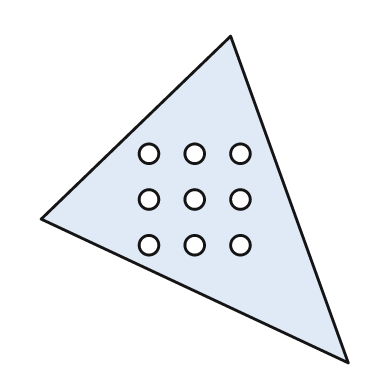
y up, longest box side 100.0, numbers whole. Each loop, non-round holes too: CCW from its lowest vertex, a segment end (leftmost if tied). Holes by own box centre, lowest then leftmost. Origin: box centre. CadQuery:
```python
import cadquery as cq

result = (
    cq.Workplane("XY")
    .moveTo(47.0, -50.0)
    .lineTo(11.0, 50.0)
    .lineTo(-47.0, -6.0)
    .close()
    .moveTo(-14.0, -14.0)
    .circle(3.0)
    .moveTo(0.0, -14.0)
    .circle(3.0)
    .moveTo(14.0, -14.0)
    .circle(3.0)
    .moveTo(-14.0, 0.0)
    .circle(3.0)
    .moveTo(0.0, 0.0)
    .circle(3.0)
    .moveTo(14.0, 0.0)
    .circle(3.0)
    .moveTo(-14.0, 14.0)
    .circle(3.0)
    .moveTo(0.0, 14.0)
    .circle(3.0)
    .moveTo(14.0, 14.0)
    .circle(3.0)
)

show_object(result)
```